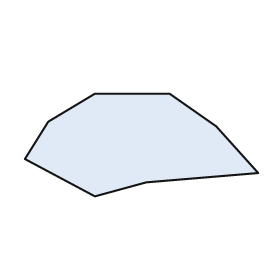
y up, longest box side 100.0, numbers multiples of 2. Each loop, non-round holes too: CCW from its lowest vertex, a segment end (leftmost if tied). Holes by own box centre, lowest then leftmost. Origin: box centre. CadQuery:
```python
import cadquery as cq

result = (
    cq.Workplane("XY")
    .moveTo(-20.0, -22.0)
    .lineTo(2.0, -16.0)
    .lineTo(50.0, -12.0)
    .lineTo(32.0, 8.0)
    .lineTo(12.0, 22.0)
    .lineTo(-20.0, 22.0)
    .lineTo(-40.0, 10.0)
    .lineTo(-50.0, -6.0)
    .close()
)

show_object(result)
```